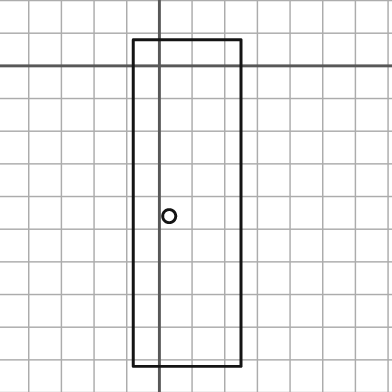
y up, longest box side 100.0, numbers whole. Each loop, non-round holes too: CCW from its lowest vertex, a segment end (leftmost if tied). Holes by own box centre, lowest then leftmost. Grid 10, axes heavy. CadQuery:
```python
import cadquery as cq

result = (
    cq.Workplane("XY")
    .moveTo(-8.0, -92.0)
    .lineTo(25.0, -92.0)
    .lineTo(25.0, 8.0)
    .lineTo(-8.0, 8.0)
    .close()
    .moveTo(3.0, -46.0)
    .circle(2.0)
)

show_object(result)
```